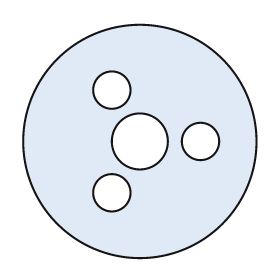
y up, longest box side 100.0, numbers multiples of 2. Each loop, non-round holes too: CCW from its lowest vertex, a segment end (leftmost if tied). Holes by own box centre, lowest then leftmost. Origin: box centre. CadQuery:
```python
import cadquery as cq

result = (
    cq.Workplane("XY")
    .moveTo(0.0, 0.0)
    .circle(50.0)
    .moveTo(-12.0, -22.0)
    .circle(8.0)
    .moveTo(0.0, 0.0)
    .circle(12.0)
    .moveTo(26.0, 0.0)
    .circle(8.0)
    .moveTo(-12.0, 22.0)
    .circle(8.0)
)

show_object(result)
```